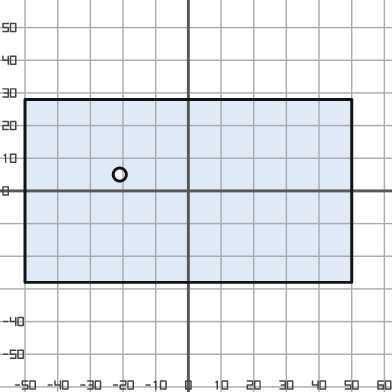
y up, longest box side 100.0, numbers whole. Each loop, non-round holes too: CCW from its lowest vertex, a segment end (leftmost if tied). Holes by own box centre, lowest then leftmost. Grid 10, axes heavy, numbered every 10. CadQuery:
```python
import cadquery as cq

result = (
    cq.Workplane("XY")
    .moveTo(-50.0, -28.0)
    .lineTo(50.0, -28.0)
    .lineTo(50.0, 28.0)
    .lineTo(-50.0, 28.0)
    .close()
    .moveTo(-21.0, 5.0)
    .circle(2.0)
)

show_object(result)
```